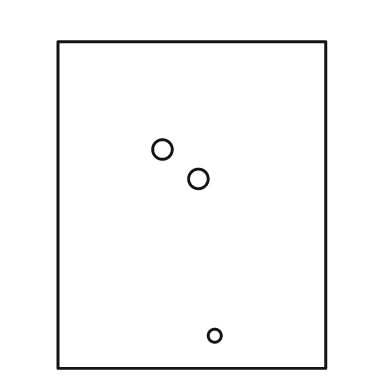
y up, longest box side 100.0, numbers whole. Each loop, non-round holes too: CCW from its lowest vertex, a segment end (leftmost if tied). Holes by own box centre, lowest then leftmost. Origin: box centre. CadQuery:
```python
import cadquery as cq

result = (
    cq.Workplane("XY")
    .moveTo(-41.0, -50.0)
    .lineTo(41.0, -50.0)
    .lineTo(41.0, 50.0)
    .lineTo(-41.0, 50.0)
    .close()
    .moveTo(7.0, -40.0)
    .circle(2.0)
    .moveTo(2.0, 8.0)
    .circle(3.0)
    .moveTo(-9.0, 17.0)
    .circle(3.0)
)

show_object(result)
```